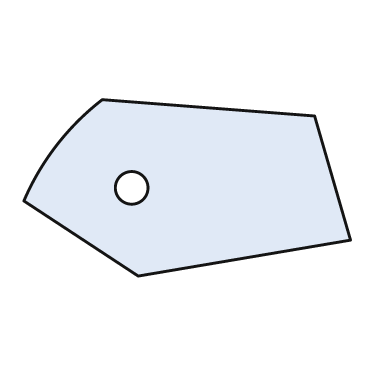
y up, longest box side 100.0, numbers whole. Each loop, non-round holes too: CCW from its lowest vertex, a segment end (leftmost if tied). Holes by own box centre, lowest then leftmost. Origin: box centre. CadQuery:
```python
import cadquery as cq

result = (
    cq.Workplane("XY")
    .moveTo(-15.0, -27.0)
    .lineTo(50.0, -16.0)
    .lineTo(39.0, 22.0)
    .lineTo(-26.0, 27.0)
    .threePointArc((-40.0, 13.0), (-50.0, -4.0))
    .close()
    .moveTo(-17.0, 0.0)
    .circle(5.0)
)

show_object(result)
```